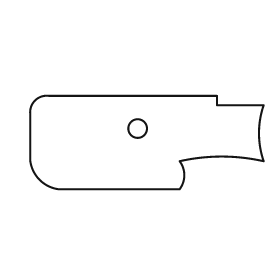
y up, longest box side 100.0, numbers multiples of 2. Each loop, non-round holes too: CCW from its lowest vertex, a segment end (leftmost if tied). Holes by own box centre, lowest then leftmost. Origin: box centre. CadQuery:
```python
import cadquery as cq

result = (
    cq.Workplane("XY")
    .moveTo(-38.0, -20.0)
    .lineTo(14.0, -20.0)
    .threePointArc((16.0, -14.0), (14.0, -8.0))
    .threePointArc((32.0, -6.0), (50.0, -8.0))
    .threePointArc((48.0, 4.0), (50.0, 16.0))
    .lineTo(30.0, 16.0)
    .lineTo(30.0, 20.0)
    .lineTo(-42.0, 20.0)
    .threePointArc((-48.0, 18.0), (-50.0, 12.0))
    .lineTo(-50.0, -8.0)
    .threePointArc((-46.0, -16.0), (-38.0, -20.0))
    .close()
    .moveTo(-4.0, 6.0)
    .circle(4.0)
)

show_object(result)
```